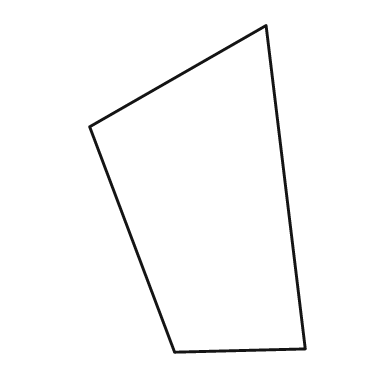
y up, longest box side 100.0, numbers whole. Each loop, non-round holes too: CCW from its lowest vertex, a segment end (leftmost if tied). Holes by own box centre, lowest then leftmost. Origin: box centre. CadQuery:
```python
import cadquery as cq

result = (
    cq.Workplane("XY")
    .moveTo(-7.0, -50.0)
    .lineTo(33.0, -49.0)
    .lineTo(21.0, 50.0)
    .lineTo(-33.0, 19.0)
    .close()
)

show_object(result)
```